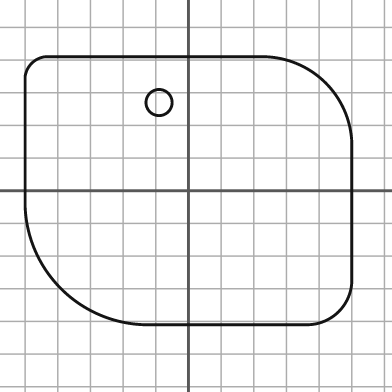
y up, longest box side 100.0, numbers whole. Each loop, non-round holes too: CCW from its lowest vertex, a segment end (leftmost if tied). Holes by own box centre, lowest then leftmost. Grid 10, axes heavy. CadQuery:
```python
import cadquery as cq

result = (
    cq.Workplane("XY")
    .moveTo(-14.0, -41.0)
    .lineTo(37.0, -41.0)
    .threePointArc((46.0, -37.0), (50.0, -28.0))
    .lineTo(50.0, 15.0)
    .threePointArc((42.0, 33.0), (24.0, 41.0))
    .lineTo(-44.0, 41.0)
    .threePointArc((-48.0, 39.0), (-50.0, 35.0))
    .lineTo(-50.0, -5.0)
    .threePointArc((-39.0, -30.0), (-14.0, -41.0))
    .close()
    .moveTo(-9.0, 27.0)
    .circle(4.0)
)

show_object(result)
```